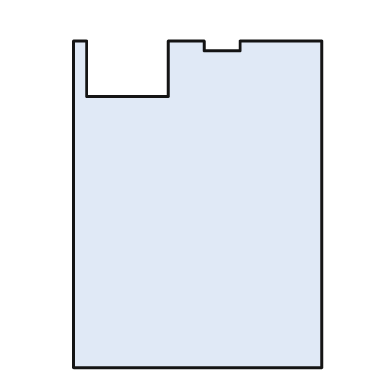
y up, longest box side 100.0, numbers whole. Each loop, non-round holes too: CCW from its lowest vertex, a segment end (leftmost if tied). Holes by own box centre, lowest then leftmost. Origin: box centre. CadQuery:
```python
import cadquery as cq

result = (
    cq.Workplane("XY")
    .moveTo(-38.0, -50.0)
    .lineTo(38.0, -50.0)
    .lineTo(38.0, 50.0)
    .lineTo(13.0, 50.0)
    .lineTo(13.0, 47.0)
    .lineTo(2.0, 47.0)
    .lineTo(2.0, 50.0)
    .lineTo(-9.0, 50.0)
    .lineTo(-9.0, 33.0)
    .lineTo(-34.0, 33.0)
    .lineTo(-34.0, 50.0)
    .lineTo(-38.0, 50.0)
    .close()
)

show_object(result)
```